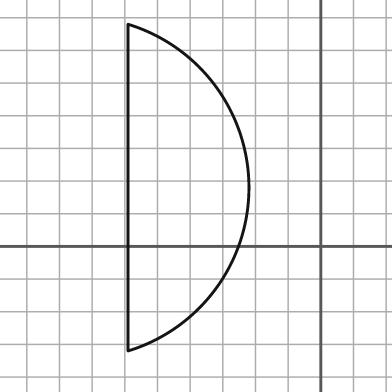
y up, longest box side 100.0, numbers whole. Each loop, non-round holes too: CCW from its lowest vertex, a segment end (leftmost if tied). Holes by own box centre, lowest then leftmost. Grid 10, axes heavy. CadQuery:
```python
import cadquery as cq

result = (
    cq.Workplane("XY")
    .moveTo(-59.0, -32.0)
    .threePointArc((-22.0, 18.0), (-59.0, 68.0))
    .close()
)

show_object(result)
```